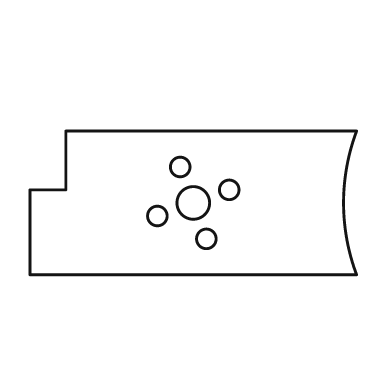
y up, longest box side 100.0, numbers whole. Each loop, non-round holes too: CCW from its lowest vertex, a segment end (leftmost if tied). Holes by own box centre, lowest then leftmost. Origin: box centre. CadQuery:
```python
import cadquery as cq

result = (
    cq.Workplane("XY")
    .moveTo(-50.0, -22.0)
    .lineTo(50.0, -22.0)
    .threePointArc((46.0, 0.0), (50.0, 22.0))
    .lineTo(-39.0, 22.0)
    .lineTo(-39.0, 4.0)
    .lineTo(-50.0, 4.0)
    .close()
    .moveTo(4.0, -11.0)
    .circle(3.0)
    .moveTo(-11.0, -4.0)
    .circle(3.0)
    .moveTo(0.0, 0.0)
    .circle(5.0)
    .moveTo(11.0, 4.0)
    .circle(3.0)
    .moveTo(-4.0, 11.0)
    .circle(3.0)
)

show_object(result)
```